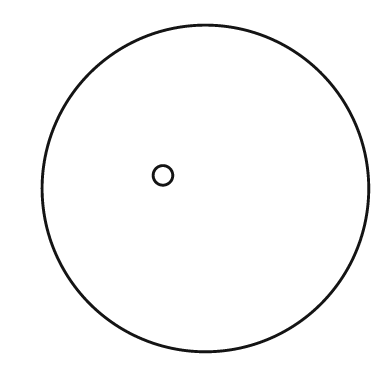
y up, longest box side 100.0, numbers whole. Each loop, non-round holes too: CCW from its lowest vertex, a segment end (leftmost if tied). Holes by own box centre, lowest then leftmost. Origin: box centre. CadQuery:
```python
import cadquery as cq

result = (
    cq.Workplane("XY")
    .moveTo(0.0, 0.0)
    .circle(50.0)
    .moveTo(-13.0, 4.0)
    .circle(3.0)
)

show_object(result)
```